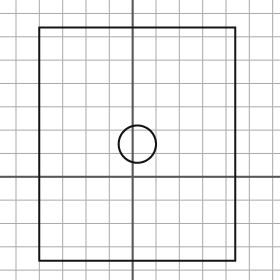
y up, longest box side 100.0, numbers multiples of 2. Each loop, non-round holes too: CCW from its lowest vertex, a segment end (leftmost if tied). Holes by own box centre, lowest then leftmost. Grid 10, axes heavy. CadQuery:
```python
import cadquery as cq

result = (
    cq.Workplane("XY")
    .moveTo(-40.0, -36.0)
    .lineTo(44.0, -36.0)
    .lineTo(44.0, 64.0)
    .lineTo(-40.0, 64.0)
    .close()
    .moveTo(2.0, 14.0)
    .circle(8.0)
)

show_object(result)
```